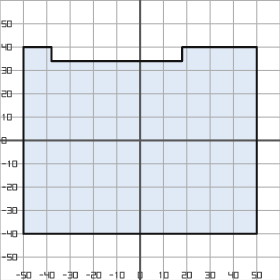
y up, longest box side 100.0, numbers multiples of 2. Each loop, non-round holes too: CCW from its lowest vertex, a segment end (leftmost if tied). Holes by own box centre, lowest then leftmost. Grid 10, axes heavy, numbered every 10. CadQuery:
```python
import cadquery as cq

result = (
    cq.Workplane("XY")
    .moveTo(-50.0, -40.0)
    .lineTo(50.0, -40.0)
    .lineTo(50.0, 40.0)
    .lineTo(18.0, 40.0)
    .lineTo(18.0, 34.0)
    .lineTo(-38.0, 34.0)
    .lineTo(-38.0, 40.0)
    .lineTo(-50.0, 40.0)
    .close()
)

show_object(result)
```